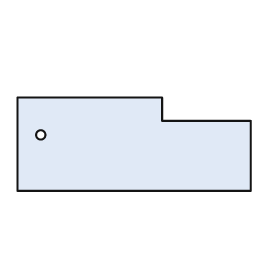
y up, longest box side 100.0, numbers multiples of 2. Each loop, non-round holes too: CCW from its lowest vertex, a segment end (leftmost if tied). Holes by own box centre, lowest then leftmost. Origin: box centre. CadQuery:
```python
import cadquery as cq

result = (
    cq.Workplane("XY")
    .moveTo(-50.0, -20.0)
    .lineTo(50.0, -20.0)
    .lineTo(50.0, 10.0)
    .lineTo(12.0, 10.0)
    .lineTo(12.0, 20.0)
    .lineTo(-50.0, 20.0)
    .close()
    .moveTo(-40.0, 4.0)
    .circle(2.0)
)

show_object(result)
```